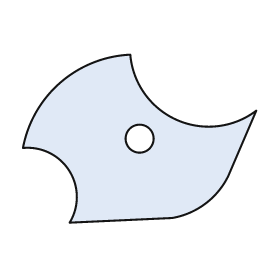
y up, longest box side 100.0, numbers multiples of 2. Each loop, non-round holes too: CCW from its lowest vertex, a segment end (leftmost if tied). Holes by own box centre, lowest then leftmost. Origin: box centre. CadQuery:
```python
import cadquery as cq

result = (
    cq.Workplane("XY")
    .moveTo(-30.0, -36.0)
    .lineTo(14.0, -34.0)
    .threePointArc((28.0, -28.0), (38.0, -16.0))
    .lineTo(50.0, 12.0)
    .threePointArc((16.0, 8.0), (-4.0, 36.0))
    .threePointArc((-34.0, 24.0), (-50.0, -4.0))
    .threePointArc((-30.0, -14.0), (-30.0, -36.0))
    .close()
    .moveTo(0.0, 0.0)
    .circle(6.0)
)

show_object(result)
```